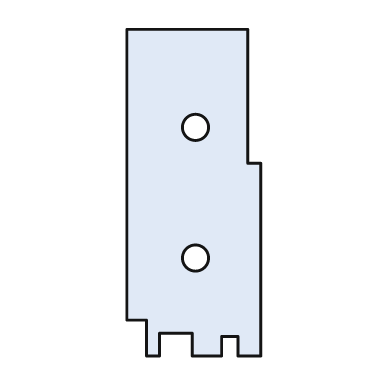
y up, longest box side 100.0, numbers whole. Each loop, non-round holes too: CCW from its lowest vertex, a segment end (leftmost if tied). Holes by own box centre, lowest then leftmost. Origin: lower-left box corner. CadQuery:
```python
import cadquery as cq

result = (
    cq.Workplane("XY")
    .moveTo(6.0, 0.0)
    .lineTo(10.0, 0.0)
    .lineTo(10.0, 7.0)
    .lineTo(20.0, 7.0)
    .lineTo(20.0, 0.0)
    .lineTo(29.0, 0.0)
    .lineTo(29.0, 6.0)
    .lineTo(34.0, 6.0)
    .lineTo(34.0, 0.0)
    .lineTo(41.0, 0.0)
    .lineTo(41.0, 59.0)
    .lineTo(37.0, 59.0)
    .lineTo(37.0, 100.0)
    .lineTo(0.0, 100.0)
    .lineTo(0.0, 11.0)
    .lineTo(6.0, 11.0)
    .close()
    .moveTo(21.0, 30.0)
    .circle(4.0)
    .moveTo(21.0, 70.0)
    .circle(4.0)
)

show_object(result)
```